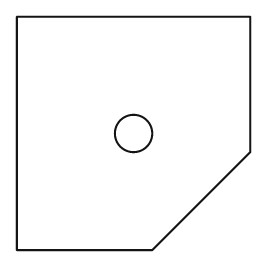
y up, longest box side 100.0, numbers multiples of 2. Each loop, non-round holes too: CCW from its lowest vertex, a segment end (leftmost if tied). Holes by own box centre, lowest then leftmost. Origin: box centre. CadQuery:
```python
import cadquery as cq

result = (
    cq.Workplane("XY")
    .moveTo(-50.0, -50.0)
    .lineTo(8.0, -50.0)
    .lineTo(50.0, -8.0)
    .lineTo(50.0, 50.0)
    .lineTo(-50.0, 50.0)
    .close()
    .moveTo(0.0, 0.0)
    .circle(8.0)
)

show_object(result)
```